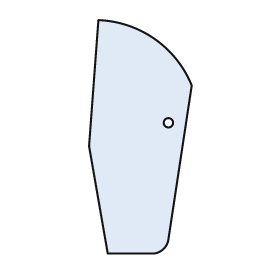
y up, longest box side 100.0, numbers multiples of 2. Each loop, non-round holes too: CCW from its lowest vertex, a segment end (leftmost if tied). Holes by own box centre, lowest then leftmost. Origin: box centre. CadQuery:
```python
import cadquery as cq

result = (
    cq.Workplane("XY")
    .moveTo(-14.0, -50.0)
    .lineTo(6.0, -50.0)
    .threePointArc((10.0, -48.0), (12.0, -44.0))
    .lineTo(22.0, 22.0)
    .threePointArc((6.0, 42.0), (-18.0, 50.0))
    .lineTo(-22.0, -4.0)
    .close()
    .moveTo(12.0, 6.0)
    .circle(2.0)
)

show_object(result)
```